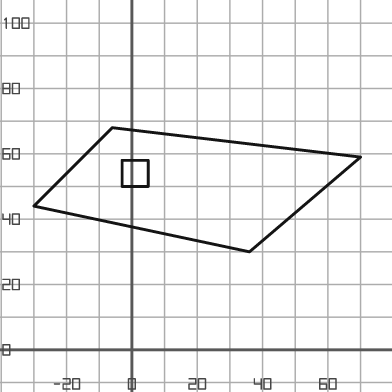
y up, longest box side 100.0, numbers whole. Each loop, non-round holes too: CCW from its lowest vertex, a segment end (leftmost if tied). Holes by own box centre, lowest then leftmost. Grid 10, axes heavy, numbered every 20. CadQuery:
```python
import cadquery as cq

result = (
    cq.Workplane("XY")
    .moveTo(36.0, 30.0)
    .lineTo(70.0, 59.0)
    .lineTo(-6.0, 68.0)
    .lineTo(-30.0, 44.0)
    .close()
    .moveTo(-3.0, 50.0)
    .lineTo(5.0, 50.0)
    .lineTo(5.0, 58.0)
    .lineTo(-3.0, 58.0)
    .close()
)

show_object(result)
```